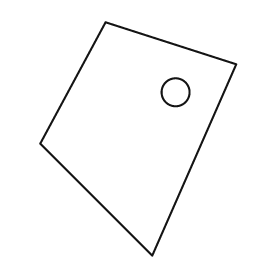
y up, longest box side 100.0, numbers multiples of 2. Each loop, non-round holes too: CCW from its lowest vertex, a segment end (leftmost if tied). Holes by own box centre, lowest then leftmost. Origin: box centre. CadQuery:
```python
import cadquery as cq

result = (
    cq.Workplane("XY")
    .moveTo(6.0, -50.0)
    .lineTo(42.0, 32.0)
    .lineTo(-14.0, 50.0)
    .lineTo(-42.0, -2.0)
    .close()
    .moveTo(16.0, 20.0)
    .circle(6.0)
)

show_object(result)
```